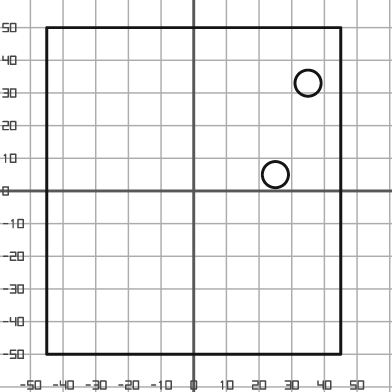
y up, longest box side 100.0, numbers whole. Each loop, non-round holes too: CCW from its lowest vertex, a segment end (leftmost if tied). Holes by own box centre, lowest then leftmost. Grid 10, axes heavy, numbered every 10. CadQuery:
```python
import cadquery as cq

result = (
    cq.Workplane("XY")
    .moveTo(-45.0, -50.0)
    .lineTo(45.0, -50.0)
    .lineTo(45.0, 50.0)
    .lineTo(-45.0, 50.0)
    .close()
    .moveTo(25.0, 5.0)
    .circle(4.0)
    .moveTo(35.0, 33.0)
    .circle(4.0)
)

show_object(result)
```